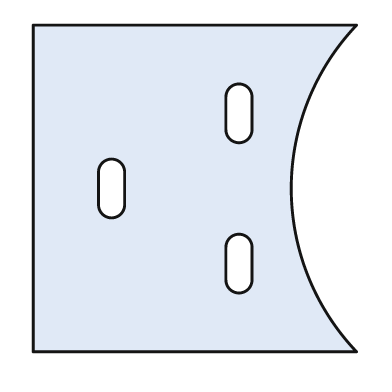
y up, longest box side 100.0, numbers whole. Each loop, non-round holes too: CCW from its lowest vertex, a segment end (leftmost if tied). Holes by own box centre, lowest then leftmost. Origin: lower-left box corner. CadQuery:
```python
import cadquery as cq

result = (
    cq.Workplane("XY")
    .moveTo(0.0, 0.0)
    .lineTo(99.0, 0.0)
    .threePointArc((79.0, 50.0), (99.0, 100.0))
    .lineTo(0.0, 100.0)
    .close()
    .moveTo(59.0, 22.0)
    .threePointArc((63.0, 18.0), (67.0, 22.0))
    .lineTo(67.0, 32.0)
    .threePointArc((63.0, 36.0), (59.0, 32.0))
    .close()
    .moveTo(20.0, 45.0)
    .threePointArc((24.0, 41.0), (28.0, 45.0))
    .lineTo(28.0, 55.0)
    .threePointArc((24.0, 59.0), (20.0, 55.0))
    .close()
    .moveTo(59.0, 68.0)
    .threePointArc((63.0, 64.0), (67.0, 68.0))
    .lineTo(67.0, 78.0)
    .threePointArc((63.0, 82.0), (59.0, 78.0))
    .close()
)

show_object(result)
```